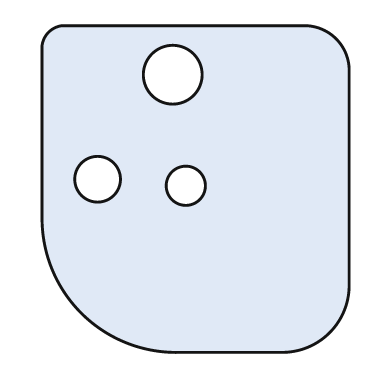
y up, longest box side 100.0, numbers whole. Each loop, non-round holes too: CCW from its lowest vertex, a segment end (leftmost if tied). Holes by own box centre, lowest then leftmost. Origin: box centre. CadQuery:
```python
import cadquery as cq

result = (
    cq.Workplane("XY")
    .moveTo(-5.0, -50.0)
    .lineTo(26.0, -50.0)
    .threePointArc((41.0, -44.0), (47.0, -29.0))
    .lineTo(47.0, 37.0)
    .threePointArc((43.0, 46.0), (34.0, 50.0))
    .lineTo(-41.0, 50.0)
    .threePointArc((-45.0, 48.0), (-47.0, 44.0))
    .lineTo(-47.0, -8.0)
    .threePointArc((-35.0, -38.0), (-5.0, -50.0))
    .close()
    .moveTo(-3.0, 1.0)
    .circle(6.0)
    .moveTo(-30.0, 3.0)
    .circle(7.0)
    .moveTo(-7.0, 35.0)
    .circle(9.0)
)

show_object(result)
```